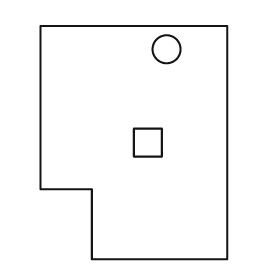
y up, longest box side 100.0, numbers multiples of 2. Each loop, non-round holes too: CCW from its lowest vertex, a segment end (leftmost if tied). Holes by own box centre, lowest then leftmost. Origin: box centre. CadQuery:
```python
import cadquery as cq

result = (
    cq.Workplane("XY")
    .moveTo(-18.0, -50.0)
    .lineTo(40.0, -50.0)
    .lineTo(40.0, 50.0)
    .lineTo(-40.0, 50.0)
    .lineTo(-40.0, -20.0)
    .lineTo(-18.0, -20.0)
    .close()
    .moveTo(0.0, -6.0)
    .lineTo(12.0, -6.0)
    .lineTo(12.0, 6.0)
    .lineTo(0.0, 6.0)
    .close()
    .moveTo(14.0, 40.0)
    .circle(6.0)
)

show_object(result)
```